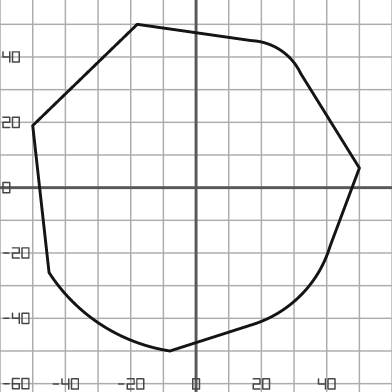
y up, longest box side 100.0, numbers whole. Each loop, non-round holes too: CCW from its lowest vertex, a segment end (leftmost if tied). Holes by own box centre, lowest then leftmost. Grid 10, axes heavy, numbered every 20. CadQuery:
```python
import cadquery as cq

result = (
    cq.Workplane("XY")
    .moveTo(-8.0, -50.0)
    .lineTo(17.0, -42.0)
    .threePointArc((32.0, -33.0), (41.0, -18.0))
    .lineTo(50.0, 6.0)
    .lineTo(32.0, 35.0)
    .threePointArc((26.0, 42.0), (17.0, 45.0))
    .lineTo(-18.0, 50.0)
    .lineTo(-50.0, 19.0)
    .lineTo(-45.0, -26.0)
    .threePointArc((-29.0, -42.0), (-8.0, -50.0))
    .close()
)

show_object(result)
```